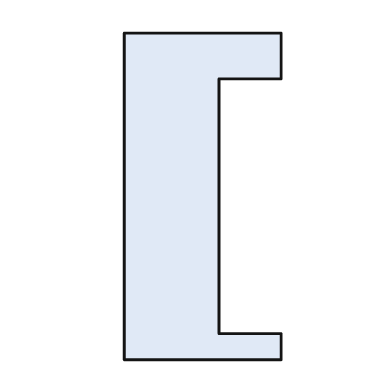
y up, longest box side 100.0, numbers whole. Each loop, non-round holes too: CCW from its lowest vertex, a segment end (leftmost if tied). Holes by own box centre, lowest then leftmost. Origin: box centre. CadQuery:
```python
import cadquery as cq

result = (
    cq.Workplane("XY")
    .moveTo(-24.0, -50.0)
    .lineTo(24.0, -50.0)
    .lineTo(24.0, -42.0)
    .lineTo(5.0, -42.0)
    .lineTo(5.0, 36.0)
    .lineTo(24.0, 36.0)
    .lineTo(24.0, 50.0)
    .lineTo(-24.0, 50.0)
    .close()
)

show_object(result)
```